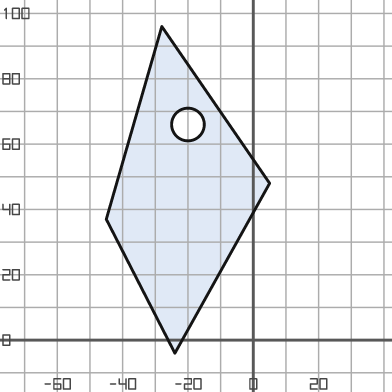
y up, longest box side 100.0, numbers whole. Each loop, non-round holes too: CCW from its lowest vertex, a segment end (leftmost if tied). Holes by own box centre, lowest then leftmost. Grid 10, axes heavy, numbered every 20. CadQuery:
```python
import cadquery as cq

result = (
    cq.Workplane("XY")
    .moveTo(-24.0, -4.0)
    .lineTo(5.0, 48.0)
    .lineTo(-28.0, 96.0)
    .lineTo(-45.0, 37.0)
    .close()
    .moveTo(-20.0, 66.0)
    .circle(5.0)
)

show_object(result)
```